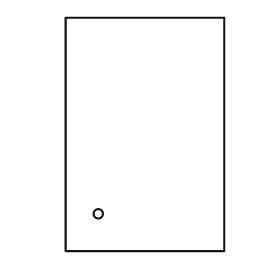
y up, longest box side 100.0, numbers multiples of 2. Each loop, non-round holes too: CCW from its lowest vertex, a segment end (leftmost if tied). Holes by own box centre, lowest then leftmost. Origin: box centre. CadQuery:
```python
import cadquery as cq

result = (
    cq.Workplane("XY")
    .moveTo(-34.0, -50.0)
    .lineTo(34.0, -50.0)
    .lineTo(34.0, 50.0)
    .lineTo(-34.0, 50.0)
    .close()
    .moveTo(-20.0, -34.0)
    .circle(2.0)
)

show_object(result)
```